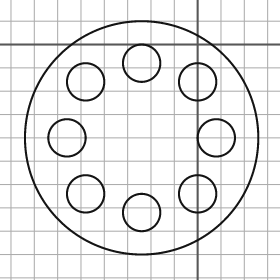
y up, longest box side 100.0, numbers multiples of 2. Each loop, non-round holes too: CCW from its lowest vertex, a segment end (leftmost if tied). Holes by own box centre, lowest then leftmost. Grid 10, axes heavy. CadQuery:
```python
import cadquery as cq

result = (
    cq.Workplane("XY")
    .moveTo(-24.0, -40.0)
    .circle(50.0)
    .moveTo(-24.0, -72.0)
    .circle(8.0)
    .moveTo(-48.0, -64.0)
    .circle(8.0)
    .moveTo(0.0, -64.0)
    .circle(8.0)
    .moveTo(-56.0, -40.0)
    .circle(8.0)
    .moveTo(8.0, -40.0)
    .circle(8.0)
    .moveTo(-48.0, -16.0)
    .circle(8.0)
    .moveTo(0.0, -16.0)
    .circle(8.0)
    .moveTo(-24.0, -8.0)
    .circle(8.0)
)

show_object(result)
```